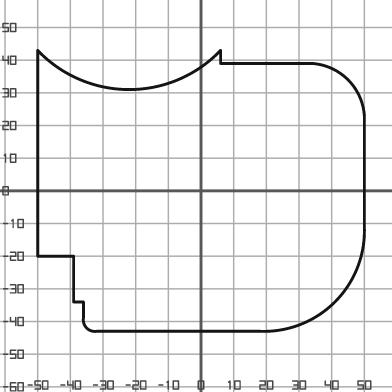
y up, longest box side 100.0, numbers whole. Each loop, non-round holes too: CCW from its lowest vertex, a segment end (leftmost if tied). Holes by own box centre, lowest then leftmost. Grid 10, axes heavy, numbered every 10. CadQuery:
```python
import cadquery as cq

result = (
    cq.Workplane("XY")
    .moveTo(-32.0, -43.0)
    .lineTo(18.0, -43.0)
    .threePointArc((41.0, -34.0), (50.0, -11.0))
    .lineTo(50.0, 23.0)
    .threePointArc((45.0, 34.0), (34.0, 39.0))
    .lineTo(6.0, 39.0)
    .lineTo(6.0, 43.0)
    .threePointArc((-22.0, 31.0), (-50.0, 43.0))
    .lineTo(-50.0, -20.0)
    .lineTo(-39.0, -20.0)
    .lineTo(-39.0, -34.0)
    .lineTo(-36.0, -34.0)
    .lineTo(-36.0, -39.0)
    .threePointArc((-35.0, -42.0), (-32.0, -43.0))
    .close()
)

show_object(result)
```